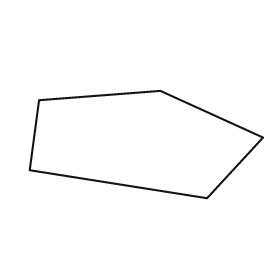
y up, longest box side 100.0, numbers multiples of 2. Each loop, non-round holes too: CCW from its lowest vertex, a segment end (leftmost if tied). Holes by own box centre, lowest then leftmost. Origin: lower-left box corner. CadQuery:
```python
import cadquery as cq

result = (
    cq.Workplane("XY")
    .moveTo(76.0, 0.0)
    .lineTo(100.0, 26.0)
    .lineTo(56.0, 46.0)
    .lineTo(4.0, 42.0)
    .lineTo(0.0, 12.0)
    .close()
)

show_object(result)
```